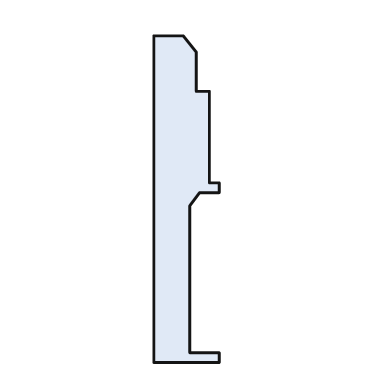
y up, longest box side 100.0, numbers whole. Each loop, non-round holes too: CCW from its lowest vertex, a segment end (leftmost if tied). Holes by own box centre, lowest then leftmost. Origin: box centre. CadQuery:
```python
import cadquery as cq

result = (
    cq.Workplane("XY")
    .moveTo(-10.0, -50.0)
    .lineTo(10.0, -50.0)
    .lineTo(10.0, -47.0)
    .lineTo(1.0, -47.0)
    .lineTo(1.0, -2.0)
    .lineTo(4.0, 2.0)
    .lineTo(10.0, 2.0)
    .lineTo(10.0, 5.0)
    .lineTo(7.0, 5.0)
    .lineTo(7.0, 33.0)
    .lineTo(3.0, 33.0)
    .lineTo(3.0, 45.0)
    .lineTo(-1.0, 50.0)
    .lineTo(-10.0, 50.0)
    .close()
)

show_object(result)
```